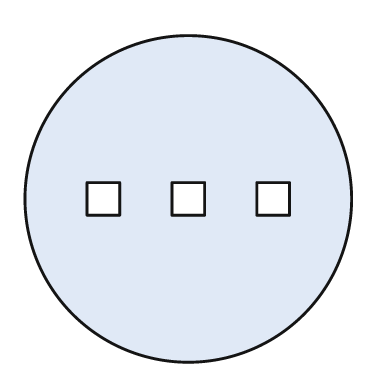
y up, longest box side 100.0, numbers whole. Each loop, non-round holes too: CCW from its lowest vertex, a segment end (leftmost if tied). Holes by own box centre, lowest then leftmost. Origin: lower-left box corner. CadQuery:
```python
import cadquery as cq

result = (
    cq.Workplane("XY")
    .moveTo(50.0, 50.0)
    .circle(50.0)
    .moveTo(19.0, 45.0)
    .lineTo(29.0, 45.0)
    .lineTo(29.0, 55.0)
    .lineTo(19.0, 55.0)
    .close()
    .moveTo(45.0, 45.0)
    .lineTo(55.0, 45.0)
    .lineTo(55.0, 55.0)
    .lineTo(45.0, 55.0)
    .close()
    .moveTo(71.0, 45.0)
    .lineTo(81.0, 45.0)
    .lineTo(81.0, 55.0)
    .lineTo(71.0, 55.0)
    .close()
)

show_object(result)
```